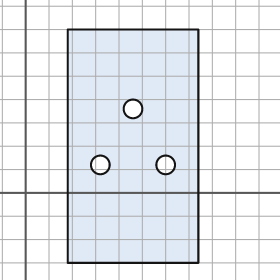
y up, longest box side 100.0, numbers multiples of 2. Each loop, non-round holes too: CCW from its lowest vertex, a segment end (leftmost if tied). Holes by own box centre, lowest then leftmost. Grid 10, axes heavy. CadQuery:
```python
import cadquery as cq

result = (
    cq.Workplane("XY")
    .moveTo(18.0, -30.0)
    .lineTo(74.0, -30.0)
    .lineTo(74.0, 70.0)
    .lineTo(18.0, 70.0)
    .close()
    .moveTo(32.0, 12.0)
    .circle(4.0)
    .moveTo(60.0, 12.0)
    .circle(4.0)
    .moveTo(46.0, 36.0)
    .circle(4.0)
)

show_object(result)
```